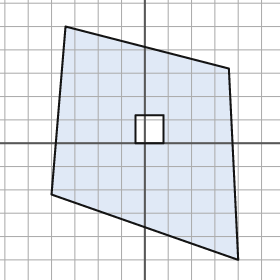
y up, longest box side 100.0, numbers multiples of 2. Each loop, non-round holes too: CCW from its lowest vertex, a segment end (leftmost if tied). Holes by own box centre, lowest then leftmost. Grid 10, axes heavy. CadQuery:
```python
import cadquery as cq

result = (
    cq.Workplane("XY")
    .moveTo(40.0, -50.0)
    .lineTo(36.0, 32.0)
    .lineTo(-34.0, 50.0)
    .lineTo(-40.0, -22.0)
    .close()
    .moveTo(-4.0, 0.0)
    .lineTo(8.0, 0.0)
    .lineTo(8.0, 12.0)
    .lineTo(-4.0, 12.0)
    .close()
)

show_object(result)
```